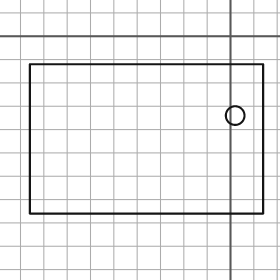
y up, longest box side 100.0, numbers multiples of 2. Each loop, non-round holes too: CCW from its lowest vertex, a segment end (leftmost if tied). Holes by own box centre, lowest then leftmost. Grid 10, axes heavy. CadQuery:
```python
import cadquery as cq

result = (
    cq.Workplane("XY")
    .moveTo(-86.0, -76.0)
    .lineTo(14.0, -76.0)
    .lineTo(14.0, -12.0)
    .lineTo(-86.0, -12.0)
    .close()
    .moveTo(2.0, -34.0)
    .circle(4.0)
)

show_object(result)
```